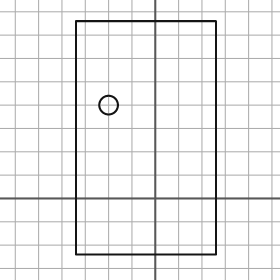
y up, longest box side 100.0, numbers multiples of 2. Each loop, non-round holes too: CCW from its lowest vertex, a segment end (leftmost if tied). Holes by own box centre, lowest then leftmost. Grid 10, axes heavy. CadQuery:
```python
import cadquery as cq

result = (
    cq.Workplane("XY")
    .moveTo(-34.0, -24.0)
    .lineTo(26.0, -24.0)
    .lineTo(26.0, 76.0)
    .lineTo(-34.0, 76.0)
    .close()
    .moveTo(-20.0, 40.0)
    .circle(4.0)
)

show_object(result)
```